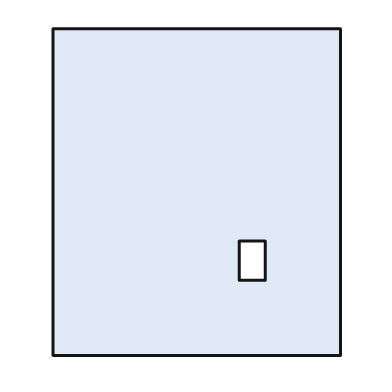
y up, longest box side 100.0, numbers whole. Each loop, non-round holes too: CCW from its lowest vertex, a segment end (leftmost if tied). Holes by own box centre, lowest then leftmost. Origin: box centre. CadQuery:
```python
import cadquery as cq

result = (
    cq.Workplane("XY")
    .moveTo(-44.0, -50.0)
    .lineTo(44.0, -50.0)
    .lineTo(44.0, 50.0)
    .lineTo(-44.0, 50.0)
    .close()
    .moveTo(13.0, -27.0)
    .lineTo(21.0, -27.0)
    .lineTo(21.0, -15.0)
    .lineTo(13.0, -15.0)
    .close()
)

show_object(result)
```